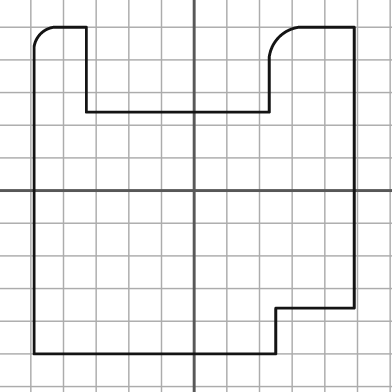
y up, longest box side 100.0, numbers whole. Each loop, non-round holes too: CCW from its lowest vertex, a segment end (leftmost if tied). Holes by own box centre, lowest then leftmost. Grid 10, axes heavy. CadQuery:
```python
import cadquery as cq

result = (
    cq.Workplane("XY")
    .moveTo(-49.0, -50.0)
    .lineTo(25.0, -50.0)
    .lineTo(25.0, -36.0)
    .lineTo(49.0, -36.0)
    .lineTo(49.0, 50.0)
    .lineTo(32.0, 50.0)
    .threePointArc((26.0, 47.0), (23.0, 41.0))
    .lineTo(23.0, 24.0)
    .lineTo(-33.0, 24.0)
    .lineTo(-33.0, 50.0)
    .lineTo(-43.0, 50.0)
    .threePointArc((-47.0, 48.0), (-49.0, 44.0))
    .close()
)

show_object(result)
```